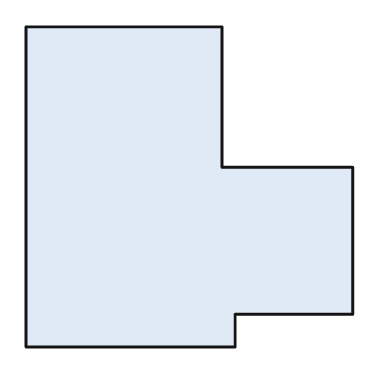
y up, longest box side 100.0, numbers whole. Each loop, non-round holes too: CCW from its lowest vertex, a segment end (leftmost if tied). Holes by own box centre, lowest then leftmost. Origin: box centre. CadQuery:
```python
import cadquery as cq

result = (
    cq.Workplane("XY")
    .moveTo(-50.0, -49.0)
    .lineTo(14.0, -49.0)
    .lineTo(14.0, -39.0)
    .lineTo(50.0, -39.0)
    .lineTo(50.0, 6.0)
    .lineTo(10.0, 6.0)
    .lineTo(10.0, 49.0)
    .lineTo(-50.0, 49.0)
    .close()
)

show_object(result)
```